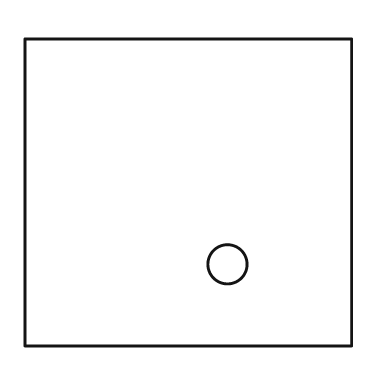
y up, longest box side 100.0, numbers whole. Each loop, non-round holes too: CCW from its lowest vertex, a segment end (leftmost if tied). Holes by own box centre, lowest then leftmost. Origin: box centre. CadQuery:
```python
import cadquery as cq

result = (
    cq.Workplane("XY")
    .moveTo(-50.0, -47.0)
    .lineTo(50.0, -47.0)
    .lineTo(50.0, 47.0)
    .lineTo(-50.0, 47.0)
    .close()
    .moveTo(12.0, -22.0)
    .circle(6.0)
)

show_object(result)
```